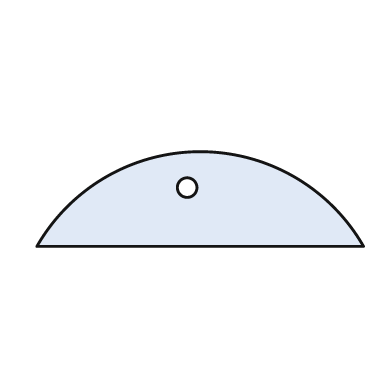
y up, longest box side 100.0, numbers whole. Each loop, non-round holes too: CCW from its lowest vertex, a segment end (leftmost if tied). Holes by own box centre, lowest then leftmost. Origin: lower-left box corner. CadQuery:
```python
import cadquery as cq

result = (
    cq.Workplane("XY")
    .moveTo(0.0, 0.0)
    .lineTo(100.0, 0.0)
    .threePointArc((50.0, 29.0), (0.0, 0.0))
    .close()
    .moveTo(46.0, 18.0)
    .circle(3.0)
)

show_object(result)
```